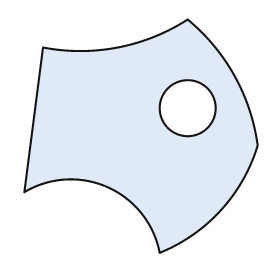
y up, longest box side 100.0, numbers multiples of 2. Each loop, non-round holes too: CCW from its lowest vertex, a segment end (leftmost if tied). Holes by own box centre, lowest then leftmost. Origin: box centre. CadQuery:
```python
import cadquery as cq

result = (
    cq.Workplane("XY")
    .moveTo(8.0, -50.0)
    .threePointArc((34.0, -32.0), (50.0, -4.0))
    .threePointArc((40.0, 26.0), (20.0, 50.0))
    .threePointArc((-10.0, 38.0), (-42.0, 38.0))
    .lineTo(-50.0, -24.0)
    .threePointArc((-14.0, -22.0), (8.0, -50.0))
    .close()
    .moveTo(20.0, 12.0)
    .circle(12.0)
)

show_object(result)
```